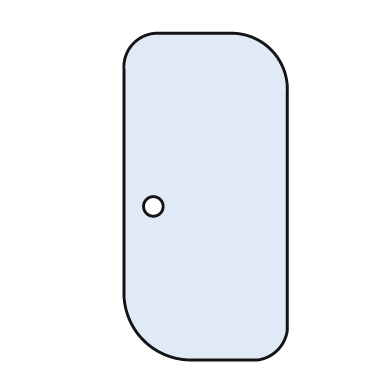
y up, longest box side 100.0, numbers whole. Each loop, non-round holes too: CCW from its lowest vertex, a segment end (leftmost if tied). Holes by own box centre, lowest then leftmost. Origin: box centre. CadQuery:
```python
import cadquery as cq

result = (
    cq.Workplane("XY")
    .moveTo(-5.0, -50.0)
    .lineTo(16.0, -50.0)
    .threePointArc((22.0, -47.0), (25.0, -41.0))
    .lineTo(25.0, 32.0)
    .threePointArc((20.0, 45.0), (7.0, 50.0))
    .lineTo(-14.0, 50.0)
    .threePointArc((-22.0, 47.0), (-25.0, 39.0))
    .lineTo(-25.0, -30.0)
    .threePointArc((-19.0, -44.0), (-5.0, -50.0))
    .close()
    .moveTo(-16.0, -3.0)
    .circle(3.0)
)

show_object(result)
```